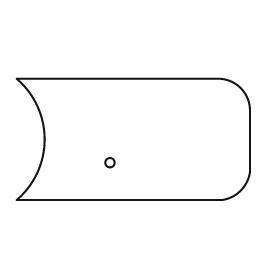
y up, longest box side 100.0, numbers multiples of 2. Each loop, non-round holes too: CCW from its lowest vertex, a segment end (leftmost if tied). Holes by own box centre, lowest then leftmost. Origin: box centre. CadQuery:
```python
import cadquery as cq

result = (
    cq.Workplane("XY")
    .moveTo(-50.0, -26.0)
    .lineTo(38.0, -26.0)
    .threePointArc((46.0, -22.0), (50.0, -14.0))
    .lineTo(50.0, 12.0)
    .threePointArc((46.0, 22.0), (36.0, 26.0))
    .lineTo(-50.0, 26.0)
    .threePointArc((-38.0, 0.0), (-50.0, -26.0))
    .close()
    .moveTo(-10.0, -10.0)
    .circle(2.0)
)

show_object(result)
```